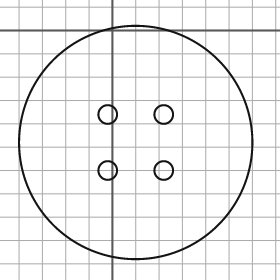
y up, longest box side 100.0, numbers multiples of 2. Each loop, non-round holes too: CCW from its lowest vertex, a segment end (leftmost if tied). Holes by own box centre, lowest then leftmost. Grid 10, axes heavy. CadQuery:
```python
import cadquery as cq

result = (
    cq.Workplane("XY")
    .moveTo(10.0, -48.0)
    .circle(50.0)
    .moveTo(-2.0, -60.0)
    .circle(4.0)
    .moveTo(22.0, -60.0)
    .circle(4.0)
    .moveTo(-2.0, -36.0)
    .circle(4.0)
    .moveTo(22.0, -36.0)
    .circle(4.0)
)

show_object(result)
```